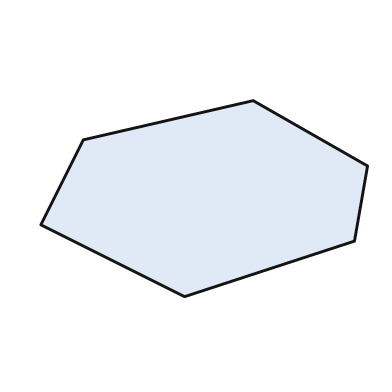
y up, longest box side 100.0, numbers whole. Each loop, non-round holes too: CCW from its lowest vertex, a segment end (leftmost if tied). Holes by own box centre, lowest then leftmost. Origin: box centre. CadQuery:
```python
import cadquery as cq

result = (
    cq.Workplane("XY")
    .moveTo(-6.0, -30.0)
    .lineTo(46.0, -13.0)
    .lineTo(50.0, 10.0)
    .lineTo(15.0, 30.0)
    .lineTo(-37.0, 18.0)
    .lineTo(-50.0, -8.0)
    .close()
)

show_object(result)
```